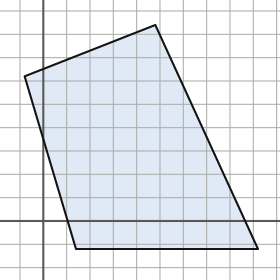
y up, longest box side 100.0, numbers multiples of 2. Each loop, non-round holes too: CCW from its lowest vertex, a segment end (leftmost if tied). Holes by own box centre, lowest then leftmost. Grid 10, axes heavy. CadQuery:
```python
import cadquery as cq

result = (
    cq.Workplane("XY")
    .moveTo(14.0, -12.0)
    .lineTo(92.0, -12.0)
    .lineTo(48.0, 84.0)
    .lineTo(-8.0, 62.0)
    .close()
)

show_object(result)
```